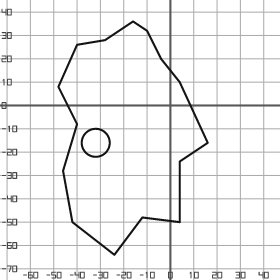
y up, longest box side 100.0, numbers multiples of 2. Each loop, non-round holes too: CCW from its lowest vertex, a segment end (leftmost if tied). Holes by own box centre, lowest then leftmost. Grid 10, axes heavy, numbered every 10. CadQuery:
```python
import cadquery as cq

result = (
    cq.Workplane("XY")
    .moveTo(-24.0, -64.0)
    .lineTo(-12.0, -48.0)
    .lineTo(4.0, -50.0)
    .lineTo(4.0, -24.0)
    .lineTo(16.0, -16.0)
    .lineTo(4.0, 10.0)
    .lineTo(-4.0, 20.0)
    .lineTo(-10.0, 32.0)
    .lineTo(-16.0, 36.0)
    .lineTo(-28.0, 28.0)
    .lineTo(-40.0, 26.0)
    .lineTo(-48.0, 8.0)
    .lineTo(-40.0, -8.0)
    .lineTo(-46.0, -28.0)
    .lineTo(-42.0, -50.0)
    .close()
    .moveTo(-32.0, -16.0)
    .circle(6.0)
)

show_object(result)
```